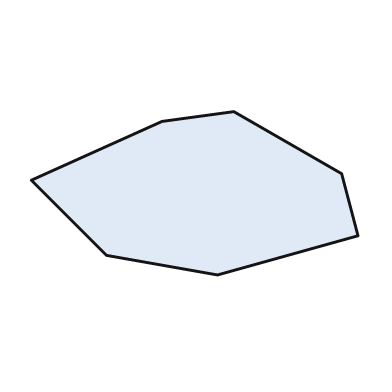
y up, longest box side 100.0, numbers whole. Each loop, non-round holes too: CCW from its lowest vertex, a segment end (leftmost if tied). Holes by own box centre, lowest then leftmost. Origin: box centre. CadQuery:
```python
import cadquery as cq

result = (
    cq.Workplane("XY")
    .moveTo(7.0, -25.0)
    .lineTo(50.0, -13.0)
    .lineTo(45.0, 6.0)
    .lineTo(12.0, 25.0)
    .lineTo(-10.0, 22.0)
    .lineTo(-50.0, 4.0)
    .lineTo(-27.0, -19.0)
    .close()
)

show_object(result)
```